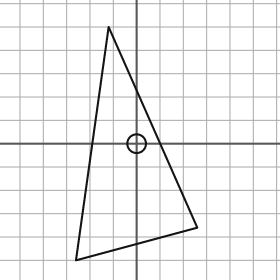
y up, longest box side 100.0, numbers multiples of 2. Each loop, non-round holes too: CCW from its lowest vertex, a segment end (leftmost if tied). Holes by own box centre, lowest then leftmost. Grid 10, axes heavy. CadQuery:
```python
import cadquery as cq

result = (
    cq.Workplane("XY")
    .moveTo(-26.0, -50.0)
    .lineTo(26.0, -36.0)
    .lineTo(-12.0, 50.0)
    .close()
    .moveTo(0.0, 0.0)
    .circle(4.0)
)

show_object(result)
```